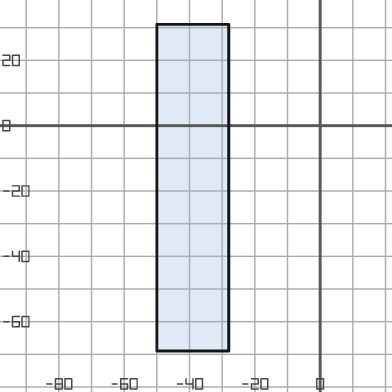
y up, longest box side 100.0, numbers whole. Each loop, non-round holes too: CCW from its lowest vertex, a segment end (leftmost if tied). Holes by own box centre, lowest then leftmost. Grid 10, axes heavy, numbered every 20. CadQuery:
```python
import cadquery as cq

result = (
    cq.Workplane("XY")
    .moveTo(-50.0, -69.0)
    .lineTo(-28.0, -69.0)
    .lineTo(-28.0, 31.0)
    .lineTo(-50.0, 31.0)
    .close()
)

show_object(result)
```